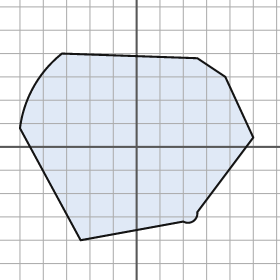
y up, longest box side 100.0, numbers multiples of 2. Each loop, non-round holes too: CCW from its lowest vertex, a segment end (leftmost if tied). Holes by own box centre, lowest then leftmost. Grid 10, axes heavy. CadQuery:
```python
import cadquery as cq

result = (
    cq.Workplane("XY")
    .moveTo(-24.0, -40.0)
    .lineTo(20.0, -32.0)
    .threePointArc((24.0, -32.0), (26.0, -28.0))
    .lineTo(50.0, 4.0)
    .lineTo(38.0, 30.0)
    .lineTo(26.0, 38.0)
    .lineTo(-32.0, 40.0)
    .threePointArc((-44.0, 26.0), (-50.0, 8.0))
    .close()
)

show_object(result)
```